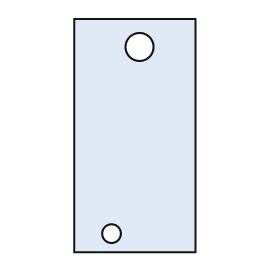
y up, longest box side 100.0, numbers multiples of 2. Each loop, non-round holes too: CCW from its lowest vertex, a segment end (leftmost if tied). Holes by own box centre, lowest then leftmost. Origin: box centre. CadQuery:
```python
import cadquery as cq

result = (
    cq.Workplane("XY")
    .moveTo(-26.0, -50.0)
    .lineTo(26.0, -50.0)
    .lineTo(26.0, 50.0)
    .lineTo(-26.0, 50.0)
    .close()
    .moveTo(-10.0, -42.0)
    .circle(4.0)
    .moveTo(2.0, 38.0)
    .circle(6.0)
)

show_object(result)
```